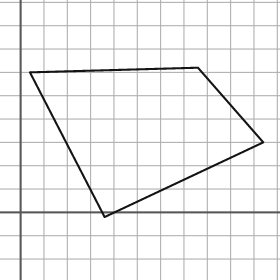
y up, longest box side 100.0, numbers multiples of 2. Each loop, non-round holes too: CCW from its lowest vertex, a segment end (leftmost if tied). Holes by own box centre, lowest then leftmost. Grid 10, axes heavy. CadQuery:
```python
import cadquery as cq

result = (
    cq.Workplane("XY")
    .moveTo(36.0, -2.0)
    .lineTo(104.0, 30.0)
    .lineTo(76.0, 62.0)
    .lineTo(4.0, 60.0)
    .close()
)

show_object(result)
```